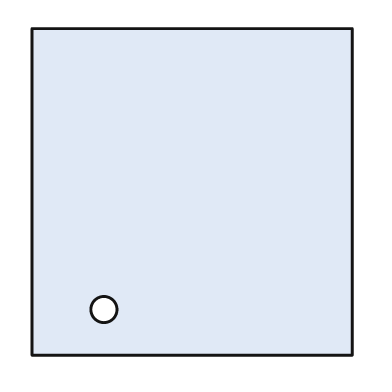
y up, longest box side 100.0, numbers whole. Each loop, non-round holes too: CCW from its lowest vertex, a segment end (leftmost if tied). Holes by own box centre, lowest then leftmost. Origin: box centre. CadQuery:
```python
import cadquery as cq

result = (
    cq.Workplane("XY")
    .moveTo(-49.0, -50.0)
    .lineTo(49.0, -50.0)
    .lineTo(49.0, 50.0)
    .lineTo(-49.0, 50.0)
    .close()
    .moveTo(-27.0, -36.0)
    .circle(4.0)
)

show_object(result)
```